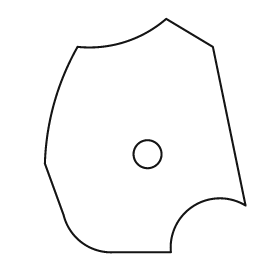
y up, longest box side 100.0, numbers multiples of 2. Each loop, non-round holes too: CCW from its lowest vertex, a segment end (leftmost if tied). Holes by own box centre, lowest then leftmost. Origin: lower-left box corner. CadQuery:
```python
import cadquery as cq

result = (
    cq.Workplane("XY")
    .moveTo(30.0, 0.0)
    .lineTo(54.0, 0.0)
    .threePointArc((64.0, 20.0), (86.0, 20.0))
    .lineTo(72.0, 88.0)
    .lineTo(52.0, 100.0)
    .threePointArc((34.0, 90.0), (14.0, 88.0))
    .threePointArc((4.0, 64.0), (0.0, 38.0))
    .lineTo(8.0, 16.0)
    .threePointArc((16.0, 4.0), (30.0, 0.0))
    .close()
    .moveTo(44.0, 42.0)
    .circle(6.0)
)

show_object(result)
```